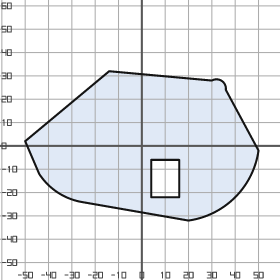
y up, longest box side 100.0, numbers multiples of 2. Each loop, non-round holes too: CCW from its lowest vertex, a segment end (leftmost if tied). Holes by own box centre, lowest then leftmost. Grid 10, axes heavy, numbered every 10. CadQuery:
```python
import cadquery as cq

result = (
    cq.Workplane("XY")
    .moveTo(20.0, -32.0)
    .threePointArc((40.0, -22.0), (50.0, -2.0))
    .lineTo(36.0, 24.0)
    .threePointArc((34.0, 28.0), (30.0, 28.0))
    .lineTo(-14.0, 32.0)
    .lineTo(-50.0, 2.0)
    .lineTo(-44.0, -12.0)
    .threePointArc((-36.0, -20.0), (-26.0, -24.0))
    .close()
    .moveTo(4.0, -22.0)
    .lineTo(16.0, -22.0)
    .lineTo(16.0, -6.0)
    .lineTo(4.0, -6.0)
    .close()
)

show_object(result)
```